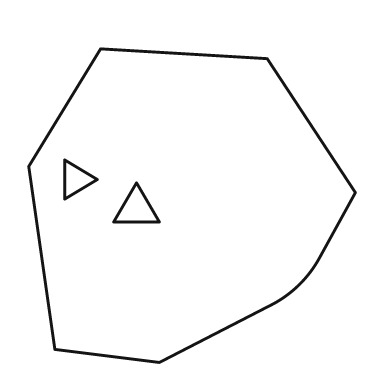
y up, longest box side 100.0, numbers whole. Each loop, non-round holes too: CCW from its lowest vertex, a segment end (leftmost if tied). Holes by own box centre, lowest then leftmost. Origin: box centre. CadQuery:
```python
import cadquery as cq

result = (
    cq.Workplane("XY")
    .moveTo(-10.0, -48.0)
    .lineTo(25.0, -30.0)
    .threePointArc((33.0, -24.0), (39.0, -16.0))
    .lineTo(50.0, 4.0)
    .lineTo(23.0, 45.0)
    .lineTo(-28.0, 48.0)
    .lineTo(-50.0, 12.0)
    .lineTo(-42.0, -44.0)
    .close()
    .moveTo(-24.0, -5.0)
    .lineTo(-10.0, -5.0)
    .lineTo(-17.0, 7.0)
    .close()
    .moveTo(-39.0, 2.0)
    .lineTo(-29.0, 8.0)
    .lineTo(-39.0, 14.0)
    .close()
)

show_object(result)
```